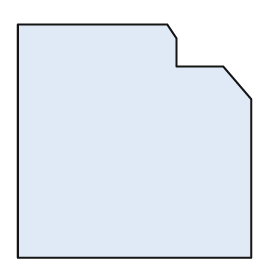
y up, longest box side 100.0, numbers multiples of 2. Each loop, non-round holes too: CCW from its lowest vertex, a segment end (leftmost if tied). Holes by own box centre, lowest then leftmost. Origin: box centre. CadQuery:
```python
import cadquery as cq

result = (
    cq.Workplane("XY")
    .moveTo(-50.0, -50.0)
    .lineTo(50.0, -50.0)
    .lineTo(50.0, 18.0)
    .lineTo(38.0, 32.0)
    .lineTo(18.0, 32.0)
    .lineTo(18.0, 44.0)
    .lineTo(14.0, 50.0)
    .lineTo(-50.0, 50.0)
    .close()
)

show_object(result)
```